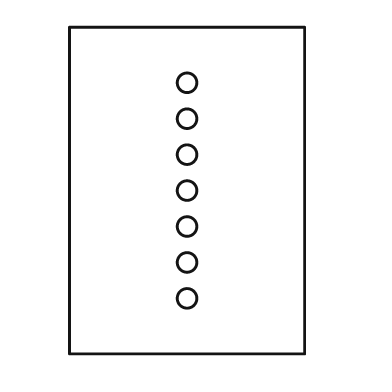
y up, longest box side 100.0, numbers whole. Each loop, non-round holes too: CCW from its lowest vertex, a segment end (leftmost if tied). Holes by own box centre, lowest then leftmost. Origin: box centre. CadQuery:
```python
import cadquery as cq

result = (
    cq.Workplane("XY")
    .moveTo(-36.0, -50.0)
    .lineTo(36.0, -50.0)
    .lineTo(36.0, 50.0)
    .lineTo(-36.0, 50.0)
    .close()
    .moveTo(0.0, -33.0)
    .circle(3.0)
    .moveTo(0.0, -22.0)
    .circle(3.0)
    .moveTo(0.0, -11.0)
    .circle(3.0)
    .moveTo(0.0, 0.0)
    .circle(3.0)
    .moveTo(0.0, 11.0)
    .circle(3.0)
    .moveTo(0.0, 22.0)
    .circle(3.0)
    .moveTo(0.0, 33.0)
    .circle(3.0)
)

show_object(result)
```